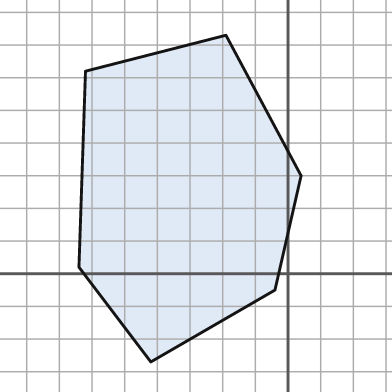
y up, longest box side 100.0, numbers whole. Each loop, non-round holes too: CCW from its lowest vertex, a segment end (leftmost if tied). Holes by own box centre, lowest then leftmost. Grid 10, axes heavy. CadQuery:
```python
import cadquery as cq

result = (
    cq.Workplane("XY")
    .moveTo(-42.0, -27.0)
    .lineTo(-4.0, -5.0)
    .lineTo(4.0, 30.0)
    .lineTo(-19.0, 73.0)
    .lineTo(-62.0, 62.0)
    .lineTo(-64.0, 2.0)
    .close()
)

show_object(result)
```